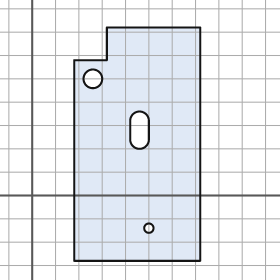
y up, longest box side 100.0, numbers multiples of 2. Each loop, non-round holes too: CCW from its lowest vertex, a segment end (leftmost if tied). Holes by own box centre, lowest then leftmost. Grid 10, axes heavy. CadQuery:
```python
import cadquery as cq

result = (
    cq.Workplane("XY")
    .moveTo(18.0, -28.0)
    .lineTo(72.0, -28.0)
    .lineTo(72.0, 72.0)
    .lineTo(32.0, 72.0)
    .lineTo(32.0, 58.0)
    .lineTo(18.0, 58.0)
    .close()
    .moveTo(50.0, -14.0)
    .circle(2.0)
    .moveTo(42.0, 24.0)
    .threePointArc((46.0, 20.0), (50.0, 24.0))
    .lineTo(50.0, 32.0)
    .threePointArc((46.0, 36.0), (42.0, 32.0))
    .close()
    .moveTo(26.0, 50.0)
    .circle(4.0)
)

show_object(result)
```